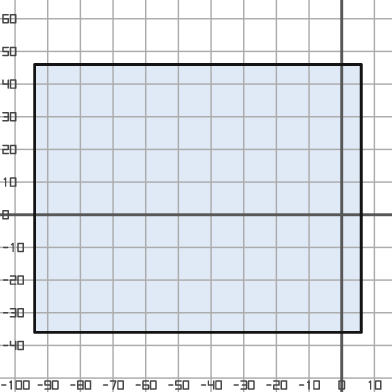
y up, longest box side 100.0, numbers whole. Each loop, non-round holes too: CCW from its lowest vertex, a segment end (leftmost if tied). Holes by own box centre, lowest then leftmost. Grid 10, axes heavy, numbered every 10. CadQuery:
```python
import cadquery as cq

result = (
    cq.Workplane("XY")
    .moveTo(-94.0, -36.0)
    .lineTo(6.0, -36.0)
    .lineTo(6.0, 46.0)
    .lineTo(-94.0, 46.0)
    .close()
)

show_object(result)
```